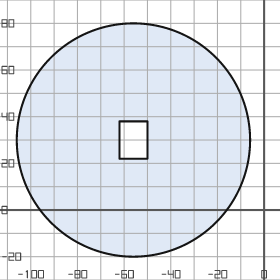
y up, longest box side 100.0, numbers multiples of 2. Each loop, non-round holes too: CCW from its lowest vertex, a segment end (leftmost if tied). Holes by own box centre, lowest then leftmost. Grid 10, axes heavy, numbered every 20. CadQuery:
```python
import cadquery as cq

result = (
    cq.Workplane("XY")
    .moveTo(-56.0, 30.0)
    .circle(50.0)
    .moveTo(-62.0, 22.0)
    .lineTo(-50.0, 22.0)
    .lineTo(-50.0, 38.0)
    .lineTo(-62.0, 38.0)
    .close()
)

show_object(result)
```